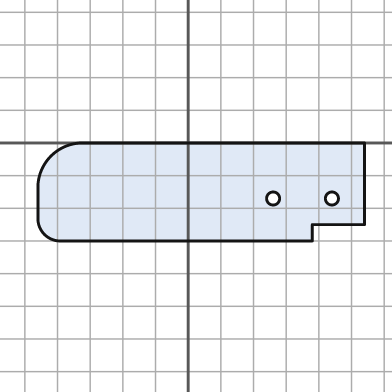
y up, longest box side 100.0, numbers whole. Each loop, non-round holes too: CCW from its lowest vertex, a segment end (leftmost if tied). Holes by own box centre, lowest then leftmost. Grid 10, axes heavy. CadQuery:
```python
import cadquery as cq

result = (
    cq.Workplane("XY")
    .moveTo(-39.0, -30.0)
    .lineTo(38.0, -30.0)
    .lineTo(38.0, -25.0)
    .lineTo(54.0, -25.0)
    .lineTo(54.0, 0.0)
    .lineTo(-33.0, 0.0)
    .threePointArc((-42.0, -4.0), (-46.0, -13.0))
    .lineTo(-46.0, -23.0)
    .threePointArc((-44.0, -28.0), (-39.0, -30.0))
    .close()
    .moveTo(26.0, -17.0)
    .circle(2.0)
    .moveTo(44.0, -17.0)
    .circle(2.0)
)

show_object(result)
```